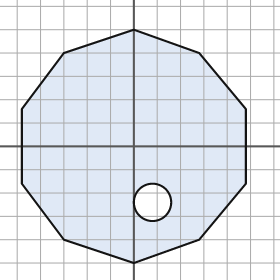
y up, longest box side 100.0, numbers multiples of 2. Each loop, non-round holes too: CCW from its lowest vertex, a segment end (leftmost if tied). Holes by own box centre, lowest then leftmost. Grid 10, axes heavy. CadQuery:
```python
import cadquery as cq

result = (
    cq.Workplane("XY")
    .moveTo(0.0, -50.0)
    .lineTo(28.0, -40.0)
    .lineTo(48.0, -16.0)
    .lineTo(48.0, 16.0)
    .lineTo(28.0, 40.0)
    .lineTo(0.0, 50.0)
    .lineTo(-30.0, 40.0)
    .lineTo(-48.0, 16.0)
    .lineTo(-48.0, -16.0)
    .lineTo(-30.0, -40.0)
    .close()
    .moveTo(8.0, -24.0)
    .circle(8.0)
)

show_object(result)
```